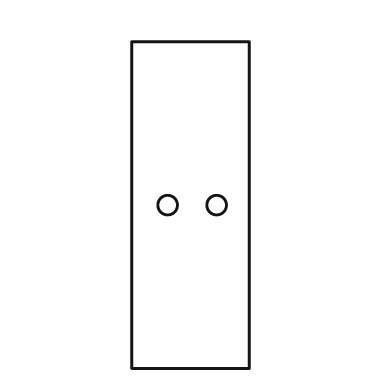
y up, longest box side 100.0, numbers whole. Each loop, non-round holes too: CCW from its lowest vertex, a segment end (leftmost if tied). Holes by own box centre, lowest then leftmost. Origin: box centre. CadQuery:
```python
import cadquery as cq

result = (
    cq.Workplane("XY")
    .moveTo(-18.0, -50.0)
    .lineTo(18.0, -50.0)
    .lineTo(18.0, 50.0)
    .lineTo(-18.0, 50.0)
    .close()
    .moveTo(-7.0, 0.0)
    .circle(3.0)
    .moveTo(8.0, 0.0)
    .circle(3.0)
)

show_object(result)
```